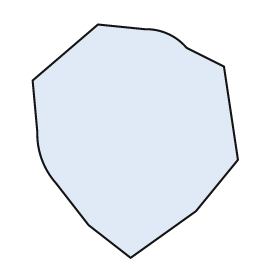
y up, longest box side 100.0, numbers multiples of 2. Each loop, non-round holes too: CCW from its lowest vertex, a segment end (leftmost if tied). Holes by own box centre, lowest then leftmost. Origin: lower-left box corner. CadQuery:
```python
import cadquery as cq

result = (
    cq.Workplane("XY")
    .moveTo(42.0, 0.0)
    .lineTo(70.0, 20.0)
    .lineTo(88.0, 42.0)
    .lineTo(82.0, 82.0)
    .lineTo(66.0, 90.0)
    .threePointArc((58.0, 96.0), (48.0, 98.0))
    .lineTo(28.0, 100.0)
    .lineTo(0.0, 76.0)
    .lineTo(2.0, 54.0)
    .threePointArc((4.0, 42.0), (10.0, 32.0))
    .lineTo(24.0, 14.0)
    .close()
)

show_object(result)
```